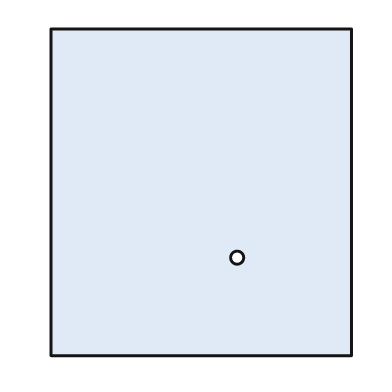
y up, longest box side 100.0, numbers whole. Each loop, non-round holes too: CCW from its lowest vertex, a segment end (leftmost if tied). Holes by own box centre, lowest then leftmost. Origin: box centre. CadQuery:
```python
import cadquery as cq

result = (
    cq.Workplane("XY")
    .moveTo(-46.0, -50.0)
    .lineTo(46.0, -50.0)
    .lineTo(46.0, 50.0)
    .lineTo(-46.0, 50.0)
    .close()
    .moveTo(11.0, -20.0)
    .circle(2.0)
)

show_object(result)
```